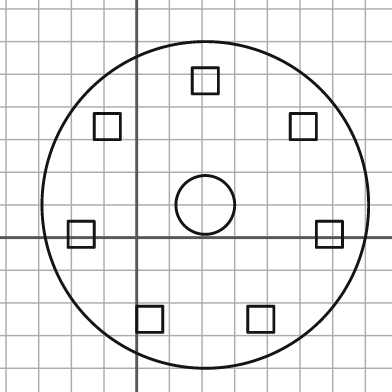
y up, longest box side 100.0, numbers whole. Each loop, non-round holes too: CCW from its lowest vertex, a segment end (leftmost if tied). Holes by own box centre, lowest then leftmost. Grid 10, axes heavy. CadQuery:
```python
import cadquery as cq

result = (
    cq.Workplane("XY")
    .moveTo(21.0, 10.0)
    .circle(50.0)
    .moveTo(0.0, -29.0)
    .lineTo(8.0, -29.0)
    .lineTo(8.0, -21.0)
    .lineTo(0.0, -21.0)
    .close()
    .moveTo(34.0, -29.0)
    .lineTo(42.0, -29.0)
    .lineTo(42.0, -21.0)
    .lineTo(34.0, -21.0)
    .close()
    .moveTo(-21.0, -3.0)
    .lineTo(-13.0, -3.0)
    .lineTo(-13.0, 5.0)
    .lineTo(-21.0, 5.0)
    .close()
    .moveTo(55.0, -3.0)
    .lineTo(63.0, -3.0)
    .lineTo(63.0, 5.0)
    .lineTo(55.0, 5.0)
    .close()
    .moveTo(21.0, 10.0)
    .circle(9.0)
    .moveTo(-13.0, 30.0)
    .lineTo(-5.0, 30.0)
    .lineTo(-5.0, 38.0)
    .lineTo(-13.0, 38.0)
    .close()
    .moveTo(47.0, 30.0)
    .lineTo(55.0, 30.0)
    .lineTo(55.0, 38.0)
    .lineTo(47.0, 38.0)
    .close()
    .moveTo(17.0, 44.0)
    .lineTo(25.0, 44.0)
    .lineTo(25.0, 52.0)
    .lineTo(17.0, 52.0)
    .close()
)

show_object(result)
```